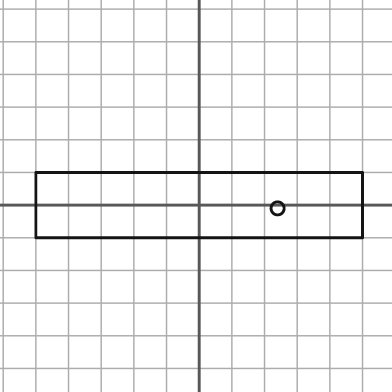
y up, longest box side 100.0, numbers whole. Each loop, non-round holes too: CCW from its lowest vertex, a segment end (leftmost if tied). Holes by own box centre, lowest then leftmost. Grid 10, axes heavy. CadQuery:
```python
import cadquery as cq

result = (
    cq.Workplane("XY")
    .moveTo(-50.0, -10.0)
    .lineTo(50.0, -10.0)
    .lineTo(50.0, 10.0)
    .lineTo(-50.0, 10.0)
    .close()
    .moveTo(24.0, -1.0)
    .circle(2.0)
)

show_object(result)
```